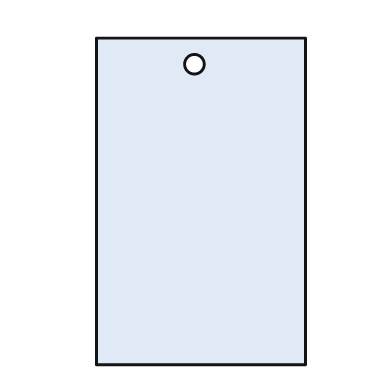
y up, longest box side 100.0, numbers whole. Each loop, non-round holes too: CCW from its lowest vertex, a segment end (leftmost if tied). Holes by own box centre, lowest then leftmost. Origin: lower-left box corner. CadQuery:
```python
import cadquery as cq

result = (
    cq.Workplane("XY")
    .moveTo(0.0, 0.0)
    .lineTo(64.0, 0.0)
    .lineTo(64.0, 100.0)
    .lineTo(0.0, 100.0)
    .close()
    .moveTo(30.0, 92.0)
    .circle(3.0)
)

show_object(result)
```